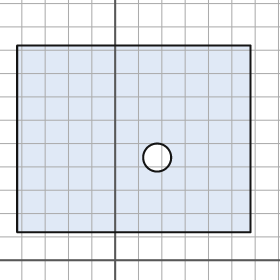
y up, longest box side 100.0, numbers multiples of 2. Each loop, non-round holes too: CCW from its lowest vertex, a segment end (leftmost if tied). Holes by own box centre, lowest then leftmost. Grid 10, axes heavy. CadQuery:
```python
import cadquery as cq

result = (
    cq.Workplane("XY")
    .moveTo(-42.0, 12.0)
    .lineTo(58.0, 12.0)
    .lineTo(58.0, 92.0)
    .lineTo(-42.0, 92.0)
    .close()
    .moveTo(18.0, 44.0)
    .circle(6.0)
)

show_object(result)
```